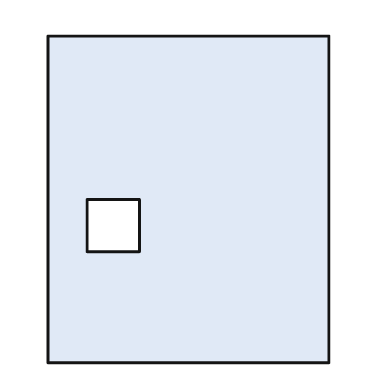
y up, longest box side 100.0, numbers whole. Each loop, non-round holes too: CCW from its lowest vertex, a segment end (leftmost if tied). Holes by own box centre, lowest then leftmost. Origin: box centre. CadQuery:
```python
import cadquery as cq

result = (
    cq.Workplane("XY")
    .moveTo(-43.0, -50.0)
    .lineTo(43.0, -50.0)
    .lineTo(43.0, 50.0)
    .lineTo(-43.0, 50.0)
    .close()
    .moveTo(-31.0, -16.0)
    .lineTo(-15.0, -16.0)
    .lineTo(-15.0, 0.0)
    .lineTo(-31.0, 0.0)
    .close()
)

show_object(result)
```